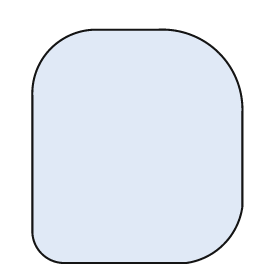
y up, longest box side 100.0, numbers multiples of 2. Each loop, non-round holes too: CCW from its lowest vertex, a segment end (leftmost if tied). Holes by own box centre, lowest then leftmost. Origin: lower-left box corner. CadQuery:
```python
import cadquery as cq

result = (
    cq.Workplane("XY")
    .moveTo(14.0, 0.0)
    .lineTo(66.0, 0.0)
    .threePointArc((82.0, 8.0), (90.0, 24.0))
    .lineTo(90.0, 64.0)
    .threePointArc((80.0, 90.0), (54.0, 100.0))
    .lineTo(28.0, 100.0)
    .threePointArc((8.0, 92.0), (0.0, 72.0))
    .lineTo(0.0, 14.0)
    .threePointArc((4.0, 4.0), (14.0, 0.0))
    .close()
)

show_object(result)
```